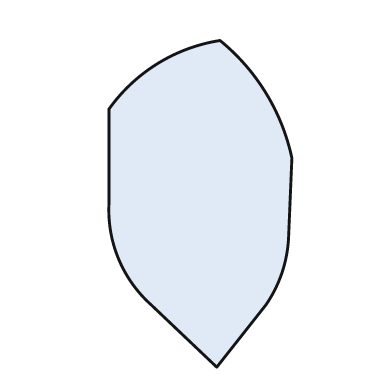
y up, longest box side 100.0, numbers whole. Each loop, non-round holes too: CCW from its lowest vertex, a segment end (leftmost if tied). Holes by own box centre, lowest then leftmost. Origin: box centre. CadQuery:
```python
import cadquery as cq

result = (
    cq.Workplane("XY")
    .moveTo(5.0, -50.0)
    .lineTo(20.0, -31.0)
    .threePointArc((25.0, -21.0), (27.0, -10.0))
    .lineTo(28.0, 14.0)
    .threePointArc((20.0, 34.0), (6.0, 50.0))
    .threePointArc((-13.0, 43.0), (-28.0, 29.0))
    .lineTo(-28.0, 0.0)
    .threePointArc((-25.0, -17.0), (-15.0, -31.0))
    .close()
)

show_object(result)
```